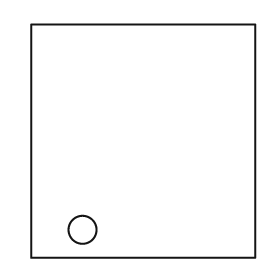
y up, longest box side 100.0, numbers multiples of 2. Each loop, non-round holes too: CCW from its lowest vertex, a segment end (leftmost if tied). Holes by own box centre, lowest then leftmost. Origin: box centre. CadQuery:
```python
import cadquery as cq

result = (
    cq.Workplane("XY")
    .moveTo(-48.0, -50.0)
    .lineTo(48.0, -50.0)
    .lineTo(48.0, 50.0)
    .lineTo(-48.0, 50.0)
    .close()
    .moveTo(-26.0, -38.0)
    .circle(6.0)
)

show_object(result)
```